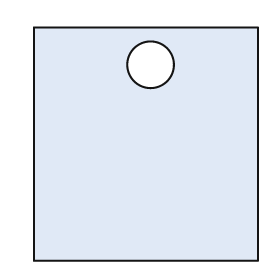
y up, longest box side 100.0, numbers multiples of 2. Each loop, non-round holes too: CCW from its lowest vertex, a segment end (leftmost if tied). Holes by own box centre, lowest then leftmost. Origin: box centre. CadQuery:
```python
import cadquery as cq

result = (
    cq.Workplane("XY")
    .moveTo(-48.0, -50.0)
    .lineTo(48.0, -50.0)
    .lineTo(48.0, 50.0)
    .lineTo(-48.0, 50.0)
    .close()
    .moveTo(2.0, 34.0)
    .circle(10.0)
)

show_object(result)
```